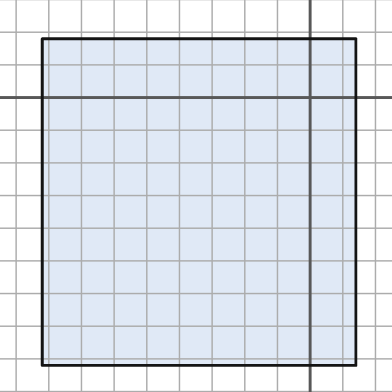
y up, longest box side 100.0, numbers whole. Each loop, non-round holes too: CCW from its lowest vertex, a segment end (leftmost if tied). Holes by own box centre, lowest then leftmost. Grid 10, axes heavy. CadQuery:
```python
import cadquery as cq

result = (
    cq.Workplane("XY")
    .moveTo(-82.0, -82.0)
    .lineTo(14.0, -82.0)
    .lineTo(14.0, 18.0)
    .lineTo(-82.0, 18.0)
    .close()
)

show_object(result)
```